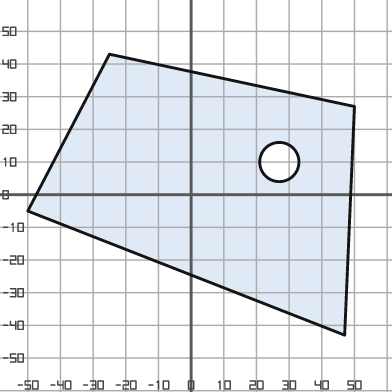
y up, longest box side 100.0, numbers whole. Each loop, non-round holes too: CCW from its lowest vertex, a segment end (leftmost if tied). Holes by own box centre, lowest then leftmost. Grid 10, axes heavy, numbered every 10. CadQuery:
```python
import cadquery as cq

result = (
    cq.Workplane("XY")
    .moveTo(47.0, -43.0)
    .lineTo(50.0, 27.0)
    .lineTo(-25.0, 43.0)
    .lineTo(-50.0, -5.0)
    .close()
    .moveTo(27.0, 10.0)
    .circle(6.0)
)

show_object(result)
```